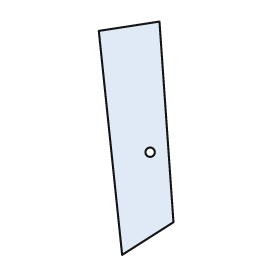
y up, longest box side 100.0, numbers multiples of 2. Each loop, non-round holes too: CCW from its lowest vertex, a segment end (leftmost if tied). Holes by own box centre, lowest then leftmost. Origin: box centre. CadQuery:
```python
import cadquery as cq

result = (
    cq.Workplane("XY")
    .moveTo(-6.0, -50.0)
    .lineTo(16.0, -36.0)
    .lineTo(10.0, 50.0)
    .lineTo(-16.0, 46.0)
    .close()
    .moveTo(6.0, -6.0)
    .circle(2.0)
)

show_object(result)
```